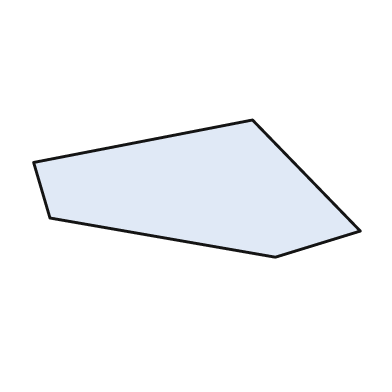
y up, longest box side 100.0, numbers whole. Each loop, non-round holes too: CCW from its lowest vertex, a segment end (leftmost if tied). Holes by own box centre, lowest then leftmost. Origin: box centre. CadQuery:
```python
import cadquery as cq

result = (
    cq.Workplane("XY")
    .moveTo(24.0, -21.0)
    .lineTo(50.0, -13.0)
    .lineTo(17.0, 21.0)
    .lineTo(-50.0, 8.0)
    .lineTo(-45.0, -9.0)
    .close()
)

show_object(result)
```